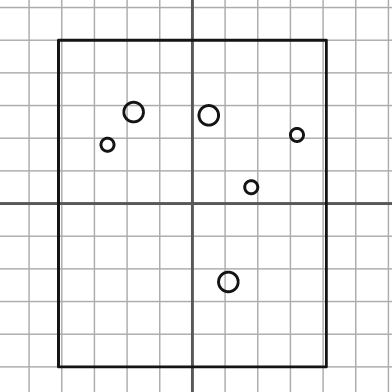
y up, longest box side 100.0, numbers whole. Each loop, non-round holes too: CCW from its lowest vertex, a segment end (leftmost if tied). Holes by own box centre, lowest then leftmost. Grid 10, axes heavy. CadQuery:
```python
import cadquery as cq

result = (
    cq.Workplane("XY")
    .moveTo(-41.0, -50.0)
    .lineTo(41.0, -50.0)
    .lineTo(41.0, 50.0)
    .lineTo(-41.0, 50.0)
    .close()
    .moveTo(11.0, -24.0)
    .circle(3.0)
    .moveTo(18.0, 5.0)
    .circle(2.0)
    .moveTo(-26.0, 18.0)
    .circle(2.0)
    .moveTo(32.0, 21.0)
    .circle(2.0)
    .moveTo(5.0, 27.0)
    .circle(3.0)
    .moveTo(-18.0, 28.0)
    .circle(3.0)
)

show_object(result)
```